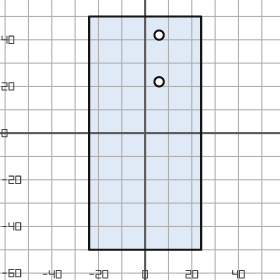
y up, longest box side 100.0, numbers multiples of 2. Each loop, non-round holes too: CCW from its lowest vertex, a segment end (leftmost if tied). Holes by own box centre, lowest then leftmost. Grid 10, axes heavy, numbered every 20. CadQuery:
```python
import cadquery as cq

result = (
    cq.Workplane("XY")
    .moveTo(-24.0, -50.0)
    .lineTo(24.0, -50.0)
    .lineTo(24.0, 50.0)
    .lineTo(-24.0, 50.0)
    .close()
    .moveTo(6.0, 22.0)
    .circle(2.0)
    .moveTo(6.0, 42.0)
    .circle(2.0)
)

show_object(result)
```